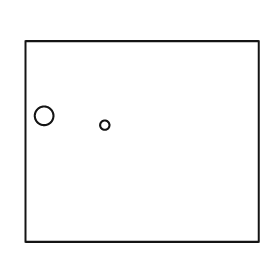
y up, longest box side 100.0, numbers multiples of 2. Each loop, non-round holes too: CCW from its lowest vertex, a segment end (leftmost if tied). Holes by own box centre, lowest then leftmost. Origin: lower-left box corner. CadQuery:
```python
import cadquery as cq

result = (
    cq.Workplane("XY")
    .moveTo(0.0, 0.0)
    .lineTo(100.0, 0.0)
    .lineTo(100.0, 86.0)
    .lineTo(0.0, 86.0)
    .close()
    .moveTo(34.0, 50.0)
    .circle(2.0)
    .moveTo(8.0, 54.0)
    .circle(4.0)
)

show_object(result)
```